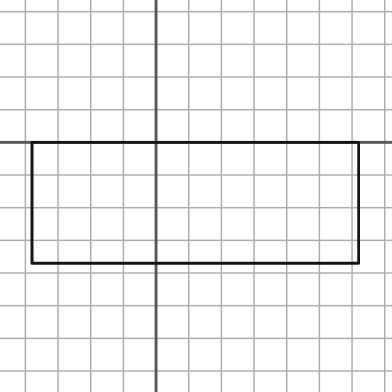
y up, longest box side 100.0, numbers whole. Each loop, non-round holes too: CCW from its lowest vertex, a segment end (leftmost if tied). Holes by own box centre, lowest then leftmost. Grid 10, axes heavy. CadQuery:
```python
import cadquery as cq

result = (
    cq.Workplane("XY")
    .moveTo(-38.0, -37.0)
    .lineTo(62.0, -37.0)
    .lineTo(62.0, 0.0)
    .lineTo(-38.0, 0.0)
    .close()
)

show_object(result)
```